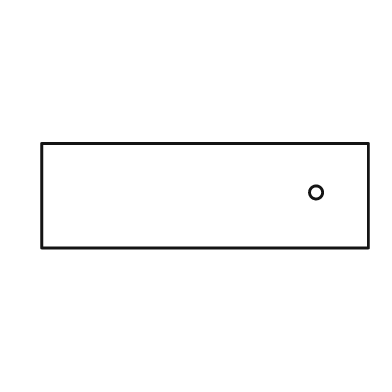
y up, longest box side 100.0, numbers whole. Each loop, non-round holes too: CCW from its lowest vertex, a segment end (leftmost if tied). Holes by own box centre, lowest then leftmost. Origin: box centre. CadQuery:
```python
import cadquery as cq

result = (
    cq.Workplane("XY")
    .moveTo(-50.0, -16.0)
    .lineTo(50.0, -16.0)
    .lineTo(50.0, 16.0)
    .lineTo(-50.0, 16.0)
    .close()
    .moveTo(34.0, 1.0)
    .circle(2.0)
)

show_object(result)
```